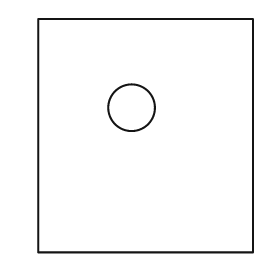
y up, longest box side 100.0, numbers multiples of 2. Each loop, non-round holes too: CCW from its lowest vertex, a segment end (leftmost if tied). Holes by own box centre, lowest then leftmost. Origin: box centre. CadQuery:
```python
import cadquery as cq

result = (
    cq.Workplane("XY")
    .moveTo(-46.0, -50.0)
    .lineTo(46.0, -50.0)
    .lineTo(46.0, 50.0)
    .lineTo(-46.0, 50.0)
    .close()
    .moveTo(-6.0, 12.0)
    .circle(10.0)
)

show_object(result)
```